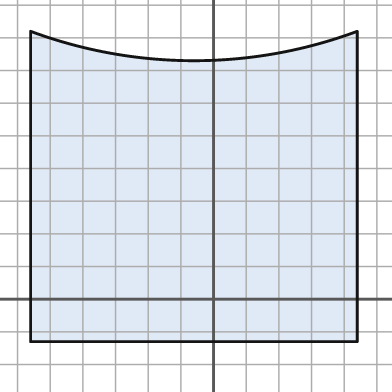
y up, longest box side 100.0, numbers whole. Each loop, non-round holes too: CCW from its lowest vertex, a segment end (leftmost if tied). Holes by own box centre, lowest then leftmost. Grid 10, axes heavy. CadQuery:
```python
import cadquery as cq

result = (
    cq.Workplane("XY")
    .moveTo(-56.0, -13.0)
    .lineTo(44.0, -13.0)
    .lineTo(44.0, 82.0)
    .threePointArc((-6.0, 73.0), (-56.0, 82.0))
    .close()
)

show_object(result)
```